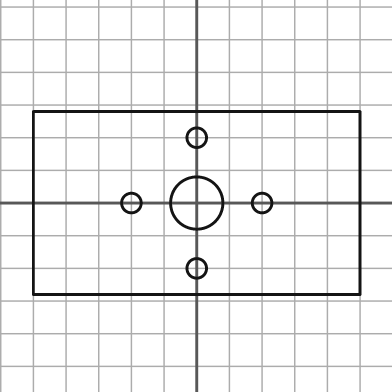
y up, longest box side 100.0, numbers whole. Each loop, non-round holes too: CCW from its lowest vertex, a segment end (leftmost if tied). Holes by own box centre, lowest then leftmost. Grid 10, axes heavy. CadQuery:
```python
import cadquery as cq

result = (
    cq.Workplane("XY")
    .moveTo(-50.0, -28.0)
    .lineTo(50.0, -28.0)
    .lineTo(50.0, 28.0)
    .lineTo(-50.0, 28.0)
    .close()
    .moveTo(0.0, -20.0)
    .circle(3.0)
    .moveTo(-20.0, 0.0)
    .circle(3.0)
    .moveTo(0.0, 0.0)
    .circle(8.0)
    .moveTo(20.0, 0.0)
    .circle(3.0)
    .moveTo(0.0, 20.0)
    .circle(3.0)
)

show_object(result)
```